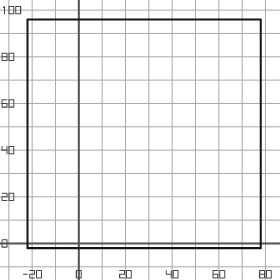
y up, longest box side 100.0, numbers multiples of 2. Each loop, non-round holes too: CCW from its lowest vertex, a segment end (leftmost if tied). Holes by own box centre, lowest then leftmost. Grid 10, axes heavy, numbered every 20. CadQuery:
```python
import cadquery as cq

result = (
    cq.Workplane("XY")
    .moveTo(-22.0, -2.0)
    .lineTo(78.0, -2.0)
    .lineTo(78.0, 96.0)
    .lineTo(-22.0, 96.0)
    .close()
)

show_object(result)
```